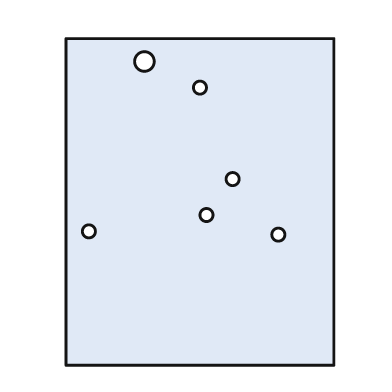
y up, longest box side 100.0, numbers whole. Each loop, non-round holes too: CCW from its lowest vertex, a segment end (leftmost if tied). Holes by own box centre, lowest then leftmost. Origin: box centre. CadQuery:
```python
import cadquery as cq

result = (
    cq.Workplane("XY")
    .moveTo(-41.0, -50.0)
    .lineTo(41.0, -50.0)
    .lineTo(41.0, 50.0)
    .lineTo(-41.0, 50.0)
    .close()
    .moveTo(24.0, -10.0)
    .circle(2.0)
    .moveTo(-34.0, -9.0)
    .circle(2.0)
    .moveTo(2.0, -4.0)
    .circle(2.0)
    .moveTo(10.0, 7.0)
    .circle(2.0)
    .moveTo(0.0, 35.0)
    .circle(2.0)
    .moveTo(-17.0, 43.0)
    .circle(3.0)
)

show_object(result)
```